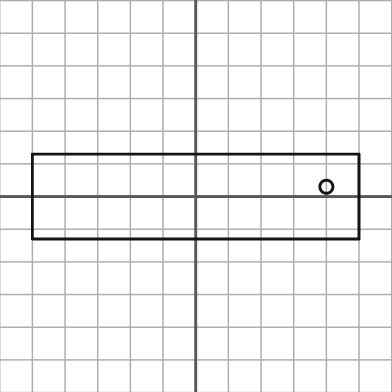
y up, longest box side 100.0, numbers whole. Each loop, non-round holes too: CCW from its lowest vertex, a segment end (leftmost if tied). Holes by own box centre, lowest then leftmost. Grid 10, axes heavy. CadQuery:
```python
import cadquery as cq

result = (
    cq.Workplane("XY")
    .moveTo(-50.0, -13.0)
    .lineTo(50.0, -13.0)
    .lineTo(50.0, 13.0)
    .lineTo(-50.0, 13.0)
    .close()
    .moveTo(40.0, 3.0)
    .circle(2.0)
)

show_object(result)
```